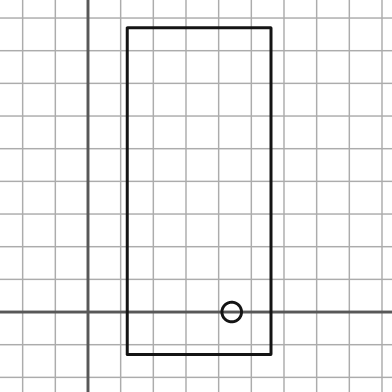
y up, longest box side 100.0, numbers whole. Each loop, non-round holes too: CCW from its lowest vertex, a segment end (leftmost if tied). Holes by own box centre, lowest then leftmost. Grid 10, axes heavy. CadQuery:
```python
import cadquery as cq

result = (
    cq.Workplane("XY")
    .moveTo(12.0, -13.0)
    .lineTo(56.0, -13.0)
    .lineTo(56.0, 87.0)
    .lineTo(12.0, 87.0)
    .close()
    .moveTo(44.0, 0.0)
    .circle(3.0)
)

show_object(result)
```